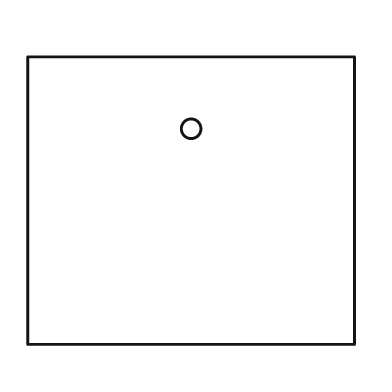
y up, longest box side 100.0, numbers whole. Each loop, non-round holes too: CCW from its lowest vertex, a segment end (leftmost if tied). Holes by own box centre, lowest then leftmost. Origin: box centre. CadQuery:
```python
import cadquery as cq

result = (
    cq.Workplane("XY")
    .moveTo(-50.0, -44.0)
    .lineTo(50.0, -44.0)
    .lineTo(50.0, 44.0)
    .lineTo(-50.0, 44.0)
    .close()
    .moveTo(0.0, 22.0)
    .circle(3.0)
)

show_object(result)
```